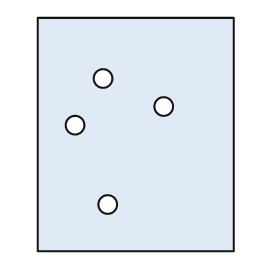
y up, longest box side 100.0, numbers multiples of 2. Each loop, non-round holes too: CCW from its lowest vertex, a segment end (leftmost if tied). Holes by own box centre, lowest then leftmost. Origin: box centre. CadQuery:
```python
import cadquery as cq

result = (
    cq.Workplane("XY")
    .moveTo(-42.0, -50.0)
    .lineTo(42.0, -50.0)
    .lineTo(42.0, 50.0)
    .lineTo(-42.0, 50.0)
    .close()
    .moveTo(-12.0, -30.0)
    .circle(4.0)
    .moveTo(-26.0, 4.0)
    .circle(4.0)
    .moveTo(12.0, 12.0)
    .circle(4.0)
    .moveTo(-14.0, 24.0)
    .circle(4.0)
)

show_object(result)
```